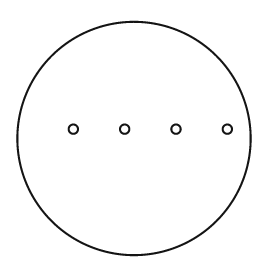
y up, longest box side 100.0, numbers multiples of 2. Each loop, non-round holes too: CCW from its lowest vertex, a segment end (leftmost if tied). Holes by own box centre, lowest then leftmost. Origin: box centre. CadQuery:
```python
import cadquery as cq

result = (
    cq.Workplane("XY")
    .moveTo(0.0, 0.0)
    .circle(50.0)
    .moveTo(-26.0, 4.0)
    .circle(2.0)
    .moveTo(-4.0, 4.0)
    .circle(2.0)
    .moveTo(18.0, 4.0)
    .circle(2.0)
    .moveTo(40.0, 4.0)
    .circle(2.0)
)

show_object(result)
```